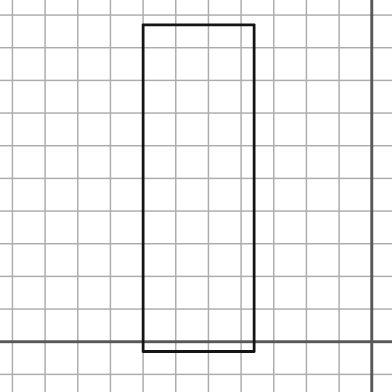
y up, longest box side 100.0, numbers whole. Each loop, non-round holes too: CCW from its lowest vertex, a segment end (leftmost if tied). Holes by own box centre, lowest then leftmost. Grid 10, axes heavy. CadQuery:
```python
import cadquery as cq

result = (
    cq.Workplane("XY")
    .moveTo(-70.0, -3.0)
    .lineTo(-36.0, -3.0)
    .lineTo(-36.0, 97.0)
    .lineTo(-70.0, 97.0)
    .close()
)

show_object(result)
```